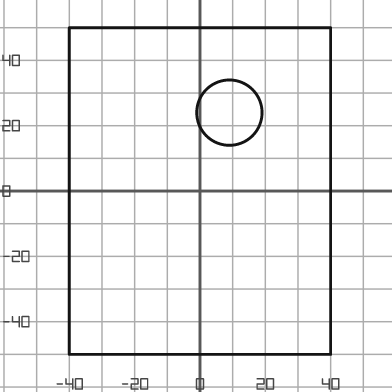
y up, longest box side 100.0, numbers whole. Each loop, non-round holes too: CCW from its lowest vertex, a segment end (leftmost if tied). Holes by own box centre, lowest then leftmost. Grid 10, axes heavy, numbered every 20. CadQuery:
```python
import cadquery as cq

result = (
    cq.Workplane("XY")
    .moveTo(-40.0, -50.0)
    .lineTo(40.0, -50.0)
    .lineTo(40.0, 50.0)
    .lineTo(-40.0, 50.0)
    .close()
    .moveTo(9.0, 24.0)
    .circle(10.0)
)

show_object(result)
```